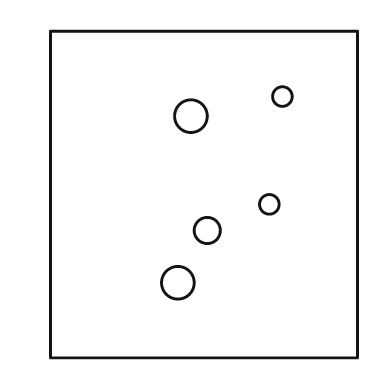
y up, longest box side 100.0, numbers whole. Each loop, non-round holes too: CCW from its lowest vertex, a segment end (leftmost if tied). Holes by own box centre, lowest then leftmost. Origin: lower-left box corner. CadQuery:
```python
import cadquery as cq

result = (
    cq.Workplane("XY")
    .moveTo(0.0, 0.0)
    .lineTo(94.0, 0.0)
    .lineTo(94.0, 100.0)
    .lineTo(0.0, 100.0)
    .close()
    .moveTo(39.0, 23.0)
    .circle(5.0)
    .moveTo(48.0, 39.0)
    .circle(4.0)
    .moveTo(67.0, 47.0)
    .circle(3.0)
    .moveTo(43.0, 74.0)
    .circle(5.0)
    .moveTo(71.0, 80.0)
    .circle(3.0)
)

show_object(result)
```